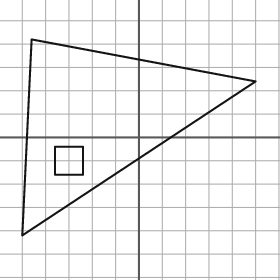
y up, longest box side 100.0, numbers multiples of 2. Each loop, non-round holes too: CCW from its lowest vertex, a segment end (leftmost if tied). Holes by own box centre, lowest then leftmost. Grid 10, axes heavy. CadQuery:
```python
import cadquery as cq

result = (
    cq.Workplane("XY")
    .moveTo(-50.0, -42.0)
    .lineTo(50.0, 24.0)
    .lineTo(-46.0, 42.0)
    .close()
    .moveTo(-36.0, -16.0)
    .lineTo(-24.0, -16.0)
    .lineTo(-24.0, -4.0)
    .lineTo(-36.0, -4.0)
    .close()
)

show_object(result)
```